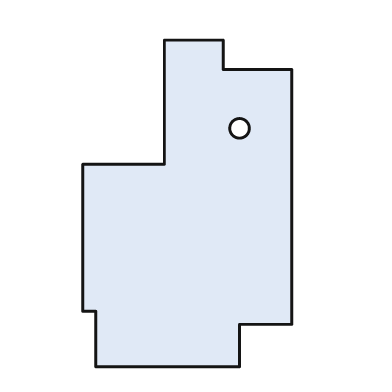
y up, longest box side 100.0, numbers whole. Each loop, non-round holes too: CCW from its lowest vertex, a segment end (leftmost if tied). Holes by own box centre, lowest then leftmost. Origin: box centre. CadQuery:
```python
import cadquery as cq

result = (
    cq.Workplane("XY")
    .moveTo(-28.0, -50.0)
    .lineTo(16.0, -50.0)
    .lineTo(16.0, -37.0)
    .lineTo(32.0, -37.0)
    .lineTo(32.0, 41.0)
    .lineTo(11.0, 41.0)
    .lineTo(11.0, 50.0)
    .lineTo(-7.0, 50.0)
    .lineTo(-7.0, 12.0)
    .lineTo(-32.0, 12.0)
    .lineTo(-32.0, -33.0)
    .lineTo(-28.0, -33.0)
    .close()
    .moveTo(16.0, 23.0)
    .circle(3.0)
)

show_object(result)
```